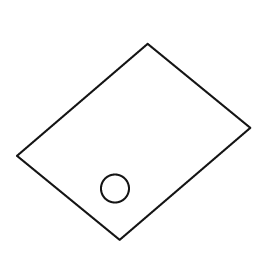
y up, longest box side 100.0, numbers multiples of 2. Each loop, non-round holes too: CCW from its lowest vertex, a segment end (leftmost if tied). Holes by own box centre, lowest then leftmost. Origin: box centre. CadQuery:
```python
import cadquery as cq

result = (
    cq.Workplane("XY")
    .moveTo(-6.0, -42.0)
    .lineTo(50.0, 6.0)
    .lineTo(6.0, 42.0)
    .lineTo(-50.0, -6.0)
    .close()
    .moveTo(-8.0, -20.0)
    .circle(6.0)
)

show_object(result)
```